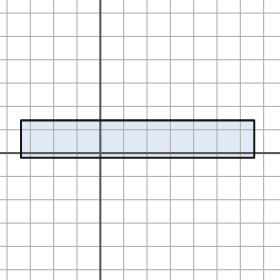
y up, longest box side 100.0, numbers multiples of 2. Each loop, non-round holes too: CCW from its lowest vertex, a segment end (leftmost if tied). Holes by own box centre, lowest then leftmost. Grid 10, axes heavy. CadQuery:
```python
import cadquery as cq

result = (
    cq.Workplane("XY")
    .moveTo(-34.0, -2.0)
    .lineTo(66.0, -2.0)
    .lineTo(66.0, 14.0)
    .lineTo(-34.0, 14.0)
    .close()
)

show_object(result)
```